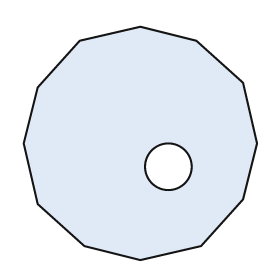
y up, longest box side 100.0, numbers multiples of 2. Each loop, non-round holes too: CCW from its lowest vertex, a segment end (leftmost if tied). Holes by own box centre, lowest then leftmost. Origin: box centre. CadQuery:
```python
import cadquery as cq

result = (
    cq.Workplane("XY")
    .moveTo(0.0, -50.0)
    .lineTo(26.0, -44.0)
    .lineTo(44.0, -24.0)
    .lineTo(50.0, 0.0)
    .lineTo(44.0, 26.0)
    .lineTo(24.0, 44.0)
    .lineTo(0.0, 50.0)
    .lineTo(-26.0, 44.0)
    .lineTo(-44.0, 24.0)
    .lineTo(-50.0, 0.0)
    .lineTo(-44.0, -26.0)
    .lineTo(-24.0, -44.0)
    .close()
    .moveTo(12.0, -10.0)
    .circle(10.0)
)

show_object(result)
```